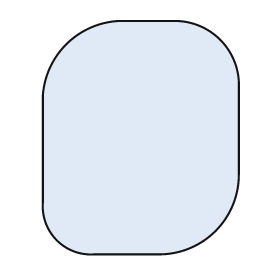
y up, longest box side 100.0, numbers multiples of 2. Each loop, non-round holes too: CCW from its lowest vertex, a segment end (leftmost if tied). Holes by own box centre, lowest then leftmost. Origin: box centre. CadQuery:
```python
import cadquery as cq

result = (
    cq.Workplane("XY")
    .moveTo(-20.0, -50.0)
    .lineTo(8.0, -50.0)
    .threePointArc((32.0, -40.0), (42.0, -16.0))
    .lineTo(42.0, 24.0)
    .threePointArc((34.0, 42.0), (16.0, 50.0))
    .lineTo(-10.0, 50.0)
    .threePointArc((-32.0, 40.0), (-42.0, 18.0))
    .lineTo(-42.0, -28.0)
    .threePointArc((-36.0, -44.0), (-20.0, -50.0))
    .close()
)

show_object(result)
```